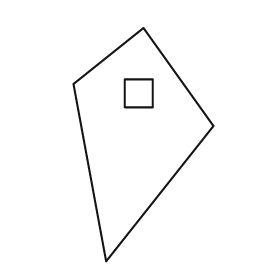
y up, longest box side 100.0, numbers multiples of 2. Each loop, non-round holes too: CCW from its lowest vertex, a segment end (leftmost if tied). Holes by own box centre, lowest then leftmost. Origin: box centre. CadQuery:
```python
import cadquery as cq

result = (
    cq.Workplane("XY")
    .moveTo(-16.0, -50.0)
    .lineTo(30.0, 8.0)
    .lineTo(0.0, 50.0)
    .lineTo(-30.0, 26.0)
    .close()
    .moveTo(-8.0, 16.0)
    .lineTo(4.0, 16.0)
    .lineTo(4.0, 28.0)
    .lineTo(-8.0, 28.0)
    .close()
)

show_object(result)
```